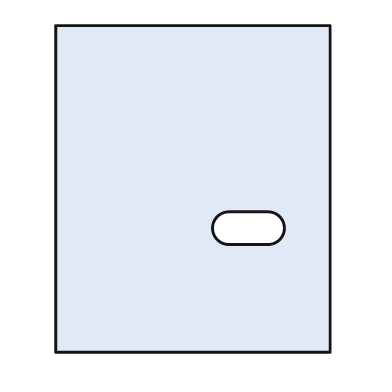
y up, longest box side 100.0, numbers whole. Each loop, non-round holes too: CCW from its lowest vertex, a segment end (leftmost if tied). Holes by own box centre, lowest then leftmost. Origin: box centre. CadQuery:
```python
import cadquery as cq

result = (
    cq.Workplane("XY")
    .moveTo(-42.0, -50.0)
    .lineTo(42.0, -50.0)
    .lineTo(42.0, 50.0)
    .lineTo(-42.0, 50.0)
    .close()
    .moveTo(11.0, -17.0)
    .lineTo(23.0, -17.0)
    .threePointArc((28.0, -12.0), (23.0, -7.0))
    .lineTo(11.0, -7.0)
    .threePointArc((6.0, -12.0), (11.0, -17.0))
    .close()
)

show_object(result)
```